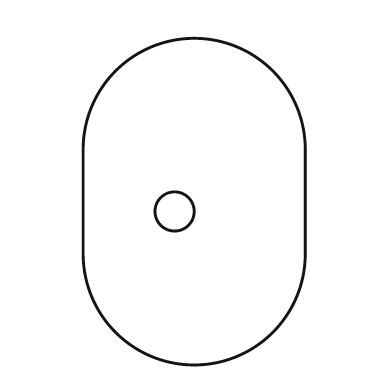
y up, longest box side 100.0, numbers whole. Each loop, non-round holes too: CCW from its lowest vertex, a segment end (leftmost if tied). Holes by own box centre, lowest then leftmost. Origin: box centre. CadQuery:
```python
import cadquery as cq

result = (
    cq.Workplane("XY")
    .moveTo(-34.0, -16.0)
    .threePointArc((0.0, -50.0), (34.0, -16.0))
    .lineTo(34.0, 16.0)
    .threePointArc((0.0, 50.0), (-34.0, 16.0))
    .close()
    .moveTo(-6.0, -3.0)
    .circle(6.0)
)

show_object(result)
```